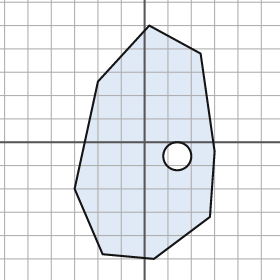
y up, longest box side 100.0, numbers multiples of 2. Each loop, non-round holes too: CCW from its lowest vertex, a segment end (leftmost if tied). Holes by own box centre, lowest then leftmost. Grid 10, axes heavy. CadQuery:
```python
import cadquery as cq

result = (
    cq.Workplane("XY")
    .moveTo(4.0, -50.0)
    .lineTo(28.0, -32.0)
    .lineTo(30.0, -4.0)
    .lineTo(24.0, 38.0)
    .lineTo(2.0, 50.0)
    .lineTo(-20.0, 26.0)
    .lineTo(-30.0, -20.0)
    .lineTo(-18.0, -48.0)
    .close()
    .moveTo(14.0, -6.0)
    .circle(6.0)
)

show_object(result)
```